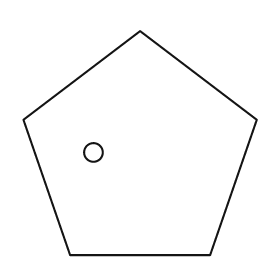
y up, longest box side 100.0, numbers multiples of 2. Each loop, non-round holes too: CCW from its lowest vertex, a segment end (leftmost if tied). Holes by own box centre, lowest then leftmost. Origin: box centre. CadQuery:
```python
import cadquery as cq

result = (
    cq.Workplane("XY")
    .moveTo(-30.0, -48.0)
    .lineTo(30.0, -48.0)
    .lineTo(50.0, 10.0)
    .lineTo(0.0, 48.0)
    .lineTo(-50.0, 10.0)
    .close()
    .moveTo(-20.0, -4.0)
    .circle(4.0)
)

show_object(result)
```